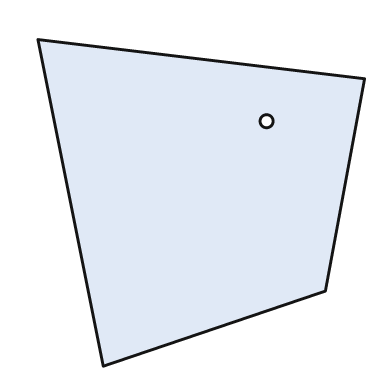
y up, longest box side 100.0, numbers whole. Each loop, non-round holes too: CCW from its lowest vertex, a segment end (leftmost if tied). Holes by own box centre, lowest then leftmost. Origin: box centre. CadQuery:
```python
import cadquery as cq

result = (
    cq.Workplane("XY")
    .moveTo(-30.0, -50.0)
    .lineTo(38.0, -27.0)
    .lineTo(50.0, 38.0)
    .lineTo(-50.0, 50.0)
    .close()
    .moveTo(20.0, 25.0)
    .circle(2.0)
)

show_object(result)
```